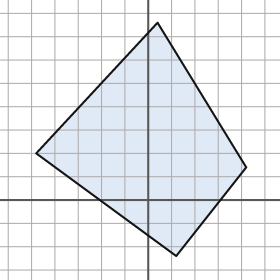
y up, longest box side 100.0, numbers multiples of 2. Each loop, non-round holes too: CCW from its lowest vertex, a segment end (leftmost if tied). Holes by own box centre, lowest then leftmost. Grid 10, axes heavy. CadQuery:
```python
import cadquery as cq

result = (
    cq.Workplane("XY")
    .moveTo(12.0, -24.0)
    .lineTo(42.0, 14.0)
    .lineTo(4.0, 76.0)
    .lineTo(-48.0, 20.0)
    .close()
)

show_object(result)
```